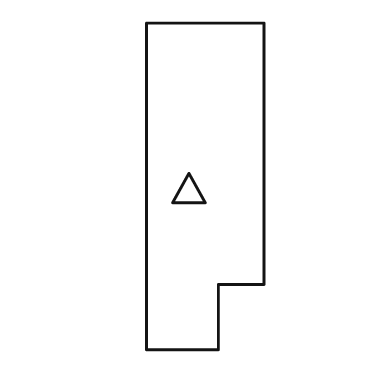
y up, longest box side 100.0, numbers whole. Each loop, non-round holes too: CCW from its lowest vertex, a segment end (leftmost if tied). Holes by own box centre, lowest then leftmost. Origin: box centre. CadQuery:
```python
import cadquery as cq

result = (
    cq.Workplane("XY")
    .moveTo(-18.0, -50.0)
    .lineTo(4.0, -50.0)
    .lineTo(4.0, -30.0)
    .lineTo(18.0, -30.0)
    .lineTo(18.0, 50.0)
    .lineTo(-18.0, 50.0)
    .close()
    .moveTo(-10.0, -5.0)
    .lineTo(0.0, -5.0)
    .lineTo(-5.0, 4.0)
    .close()
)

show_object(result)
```